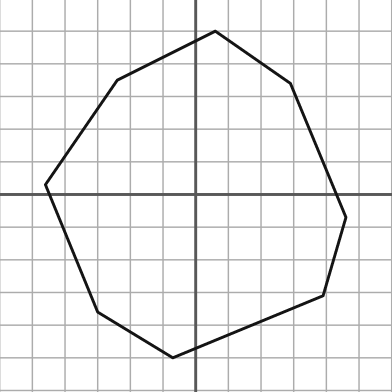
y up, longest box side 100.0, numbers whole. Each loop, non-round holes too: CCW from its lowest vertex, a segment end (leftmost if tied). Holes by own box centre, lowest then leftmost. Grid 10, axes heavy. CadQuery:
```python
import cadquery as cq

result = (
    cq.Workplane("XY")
    .moveTo(-7.0, -50.0)
    .lineTo(39.0, -31.0)
    .lineTo(46.0, -7.0)
    .lineTo(29.0, 34.0)
    .lineTo(6.0, 50.0)
    .lineTo(-24.0, 35.0)
    .lineTo(-46.0, 3.0)
    .lineTo(-30.0, -36.0)
    .close()
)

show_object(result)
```